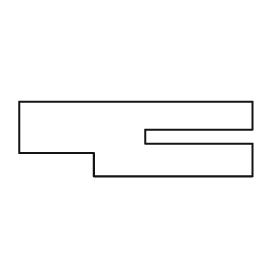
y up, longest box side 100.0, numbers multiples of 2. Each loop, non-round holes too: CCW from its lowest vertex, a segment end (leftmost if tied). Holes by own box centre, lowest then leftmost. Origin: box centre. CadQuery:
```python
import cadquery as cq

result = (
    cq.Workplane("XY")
    .moveTo(-18.0, -16.0)
    .lineTo(50.0, -16.0)
    .lineTo(50.0, -2.0)
    .lineTo(4.0, -2.0)
    .lineTo(4.0, 4.0)
    .lineTo(50.0, 4.0)
    .lineTo(50.0, 16.0)
    .lineTo(-50.0, 16.0)
    .lineTo(-50.0, -6.0)
    .lineTo(-18.0, -6.0)
    .close()
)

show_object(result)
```